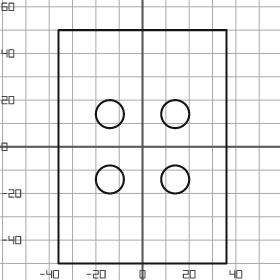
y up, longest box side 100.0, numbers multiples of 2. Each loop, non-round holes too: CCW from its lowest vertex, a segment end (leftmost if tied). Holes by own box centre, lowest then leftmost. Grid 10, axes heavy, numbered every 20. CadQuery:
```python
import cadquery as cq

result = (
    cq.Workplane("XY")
    .moveTo(-36.0, -50.0)
    .lineTo(36.0, -50.0)
    .lineTo(36.0, 50.0)
    .lineTo(-36.0, 50.0)
    .close()
    .moveTo(-14.0, -14.0)
    .circle(6.0)
    .moveTo(14.0, -14.0)
    .circle(6.0)
    .moveTo(-14.0, 14.0)
    .circle(6.0)
    .moveTo(14.0, 14.0)
    .circle(6.0)
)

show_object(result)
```